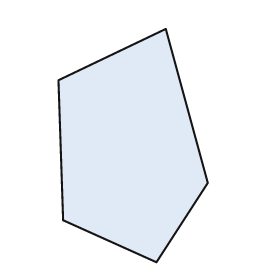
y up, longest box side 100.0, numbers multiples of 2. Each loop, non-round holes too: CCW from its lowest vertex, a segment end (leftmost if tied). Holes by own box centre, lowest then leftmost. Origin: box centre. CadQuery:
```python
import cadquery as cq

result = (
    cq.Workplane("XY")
    .moveTo(10.0, -50.0)
    .lineTo(32.0, -16.0)
    .lineTo(14.0, 50.0)
    .lineTo(-32.0, 28.0)
    .lineTo(-30.0, -32.0)
    .close()
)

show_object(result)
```